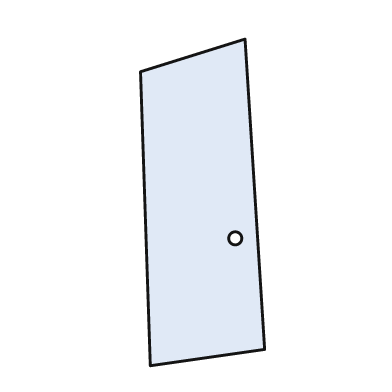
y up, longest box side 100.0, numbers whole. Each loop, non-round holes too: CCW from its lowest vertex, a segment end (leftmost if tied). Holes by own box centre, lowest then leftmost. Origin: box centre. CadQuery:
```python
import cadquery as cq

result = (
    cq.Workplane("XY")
    .moveTo(-16.0, -50.0)
    .lineTo(19.0, -45.0)
    .lineTo(13.0, 50.0)
    .lineTo(-19.0, 40.0)
    .close()
    .moveTo(10.0, -11.0)
    .circle(2.0)
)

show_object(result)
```